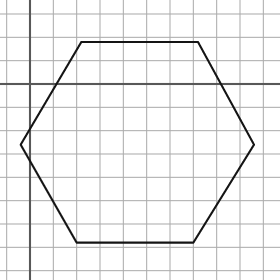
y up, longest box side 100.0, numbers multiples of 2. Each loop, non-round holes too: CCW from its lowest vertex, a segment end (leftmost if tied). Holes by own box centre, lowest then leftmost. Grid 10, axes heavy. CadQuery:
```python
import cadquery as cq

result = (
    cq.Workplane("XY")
    .moveTo(20.0, -68.0)
    .lineTo(70.0, -68.0)
    .lineTo(96.0, -26.0)
    .lineTo(72.0, 18.0)
    .lineTo(22.0, 18.0)
    .lineTo(-4.0, -26.0)
    .close()
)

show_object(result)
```